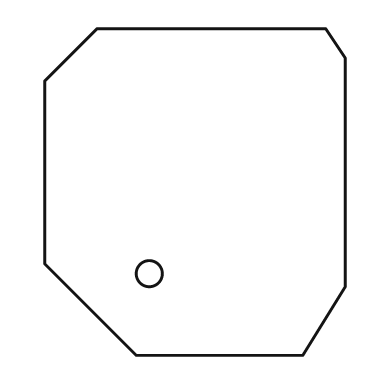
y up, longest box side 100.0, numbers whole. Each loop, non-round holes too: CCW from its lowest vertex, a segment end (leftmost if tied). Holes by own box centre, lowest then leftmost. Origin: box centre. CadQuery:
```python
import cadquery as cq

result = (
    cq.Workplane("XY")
    .moveTo(-18.0, -50.0)
    .lineTo(33.0, -50.0)
    .lineTo(46.0, -29.0)
    .lineTo(46.0, 41.0)
    .lineTo(40.0, 50.0)
    .lineTo(-30.0, 50.0)
    .lineTo(-46.0, 34.0)
    .lineTo(-46.0, -22.0)
    .close()
    .moveTo(-14.0, -25.0)
    .circle(4.0)
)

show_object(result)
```